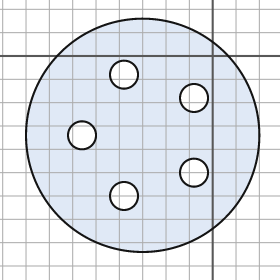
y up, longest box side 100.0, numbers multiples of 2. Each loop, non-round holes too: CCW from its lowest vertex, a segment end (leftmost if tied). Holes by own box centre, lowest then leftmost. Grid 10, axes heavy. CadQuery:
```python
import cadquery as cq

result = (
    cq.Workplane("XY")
    .moveTo(-30.0, -34.0)
    .circle(50.0)
    .moveTo(-38.0, -60.0)
    .circle(6.0)
    .moveTo(-8.0, -50.0)
    .circle(6.0)
    .moveTo(-56.0, -34.0)
    .circle(6.0)
    .moveTo(-8.0, -18.0)
    .circle(6.0)
    .moveTo(-38.0, -8.0)
    .circle(6.0)
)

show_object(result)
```